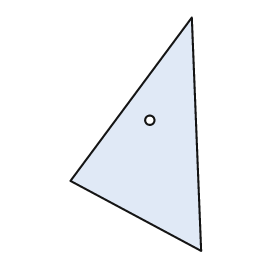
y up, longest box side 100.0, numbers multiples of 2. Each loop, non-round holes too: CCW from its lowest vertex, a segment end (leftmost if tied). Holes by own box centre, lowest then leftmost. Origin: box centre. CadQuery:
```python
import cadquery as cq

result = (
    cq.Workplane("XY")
    .moveTo(28.0, -50.0)
    .lineTo(24.0, 50.0)
    .lineTo(-28.0, -20.0)
    .close()
    .moveTo(6.0, 6.0)
    .circle(2.0)
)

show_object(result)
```